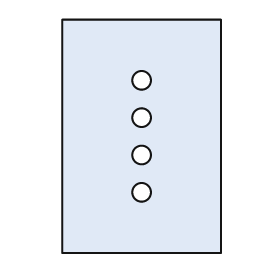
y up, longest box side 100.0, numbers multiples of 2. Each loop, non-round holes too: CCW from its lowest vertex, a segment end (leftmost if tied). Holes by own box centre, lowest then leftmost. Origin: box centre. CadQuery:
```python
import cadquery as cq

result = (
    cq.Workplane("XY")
    .moveTo(-34.0, -50.0)
    .lineTo(34.0, -50.0)
    .lineTo(34.0, 50.0)
    .lineTo(-34.0, 50.0)
    .close()
    .moveTo(0.0, -24.0)
    .circle(4.0)
    .moveTo(0.0, -8.0)
    .circle(4.0)
    .moveTo(0.0, 8.0)
    .circle(4.0)
    .moveTo(0.0, 24.0)
    .circle(4.0)
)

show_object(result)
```